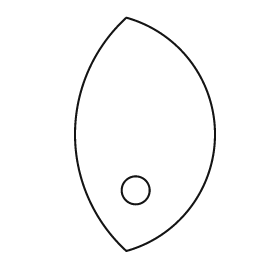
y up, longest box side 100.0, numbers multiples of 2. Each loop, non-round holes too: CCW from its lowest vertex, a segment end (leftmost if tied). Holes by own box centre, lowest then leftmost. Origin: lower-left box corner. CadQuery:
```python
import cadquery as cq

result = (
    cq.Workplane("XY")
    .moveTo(22.0, 0.0)
    .threePointArc((60.0, 50.0), (22.0, 100.0))
    .threePointArc((0.0, 50.0), (22.0, 0.0))
    .close()
    .moveTo(26.0, 26.0)
    .circle(6.0)
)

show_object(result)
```